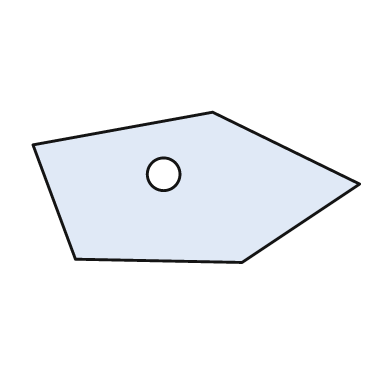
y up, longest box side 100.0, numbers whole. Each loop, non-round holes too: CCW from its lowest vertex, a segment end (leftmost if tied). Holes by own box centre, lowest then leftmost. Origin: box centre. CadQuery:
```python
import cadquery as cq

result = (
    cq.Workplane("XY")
    .moveTo(14.0, -23.0)
    .lineTo(50.0, 1.0)
    .lineTo(5.0, 23.0)
    .lineTo(-50.0, 13.0)
    .lineTo(-37.0, -22.0)
    .close()
    .moveTo(-10.0, 4.0)
    .circle(5.0)
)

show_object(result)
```